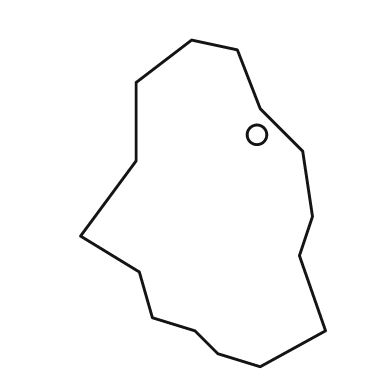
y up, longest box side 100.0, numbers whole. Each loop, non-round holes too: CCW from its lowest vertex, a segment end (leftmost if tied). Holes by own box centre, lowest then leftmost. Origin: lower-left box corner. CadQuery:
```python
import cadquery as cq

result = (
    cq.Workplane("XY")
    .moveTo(55.0, 0.0)
    .lineTo(75.0, 11.0)
    .lineTo(67.0, 34.0)
    .lineTo(71.0, 46.0)
    .lineTo(68.0, 66.0)
    .lineTo(55.0, 79.0)
    .lineTo(48.0, 97.0)
    .lineTo(34.0, 100.0)
    .lineTo(17.0, 87.0)
    .lineTo(17.0, 63.0)
    .lineTo(0.0, 40.0)
    .lineTo(18.0, 29.0)
    .lineTo(22.0, 15.0)
    .lineTo(35.0, 11.0)
    .lineTo(42.0, 4.0)
    .close()
    .moveTo(54.0, 71.0)
    .circle(3.0)
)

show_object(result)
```